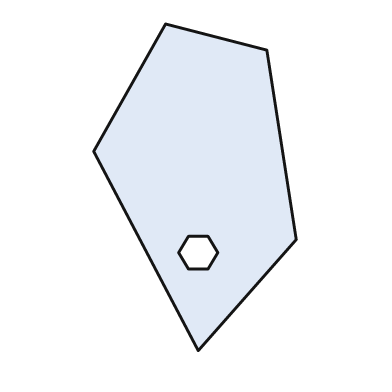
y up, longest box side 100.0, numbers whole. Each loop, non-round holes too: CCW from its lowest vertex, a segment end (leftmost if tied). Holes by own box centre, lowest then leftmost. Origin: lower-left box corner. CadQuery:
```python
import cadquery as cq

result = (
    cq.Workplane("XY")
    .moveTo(32.0, 0.0)
    .lineTo(62.0, 34.0)
    .lineTo(53.0, 92.0)
    .lineTo(22.0, 100.0)
    .lineTo(0.0, 61.0)
    .close()
    .moveTo(29.0, 25.0)
    .lineTo(35.0, 25.0)
    .lineTo(38.0, 30.0)
    .lineTo(35.0, 35.0)
    .lineTo(29.0, 35.0)
    .lineTo(26.0, 30.0)
    .close()
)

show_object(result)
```